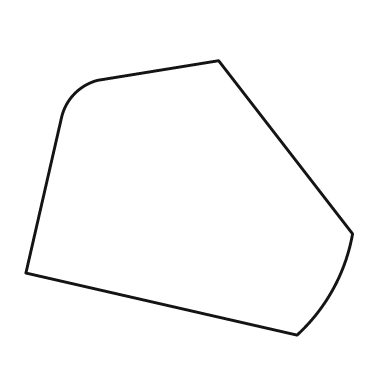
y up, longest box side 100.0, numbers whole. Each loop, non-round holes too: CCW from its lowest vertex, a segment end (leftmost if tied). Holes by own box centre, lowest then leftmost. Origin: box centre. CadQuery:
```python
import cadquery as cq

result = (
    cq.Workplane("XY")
    .moveTo(33.0, -42.0)
    .threePointArc((44.0, -28.0), (50.0, -11.0))
    .lineTo(9.0, 42.0)
    .lineTo(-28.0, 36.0)
    .threePointArc((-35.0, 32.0), (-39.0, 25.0))
    .lineTo(-50.0, -23.0)
    .close()
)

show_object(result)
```